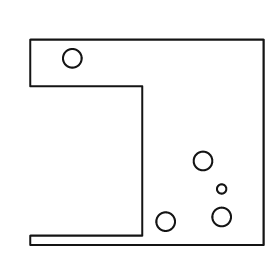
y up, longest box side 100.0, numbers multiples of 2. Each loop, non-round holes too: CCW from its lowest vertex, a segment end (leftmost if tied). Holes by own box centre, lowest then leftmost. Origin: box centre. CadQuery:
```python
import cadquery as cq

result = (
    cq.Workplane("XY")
    .moveTo(-50.0, -44.0)
    .lineTo(50.0, -44.0)
    .lineTo(50.0, 44.0)
    .lineTo(-50.0, 44.0)
    .lineTo(-50.0, 24.0)
    .lineTo(-2.0, 24.0)
    .lineTo(-2.0, -40.0)
    .lineTo(-50.0, -40.0)
    .close()
    .moveTo(8.0, -34.0)
    .circle(4.0)
    .moveTo(32.0, -32.0)
    .circle(4.0)
    .moveTo(32.0, -20.0)
    .circle(2.0)
    .moveTo(24.0, -8.0)
    .circle(4.0)
    .moveTo(-32.0, 36.0)
    .circle(4.0)
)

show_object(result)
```